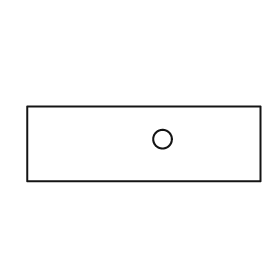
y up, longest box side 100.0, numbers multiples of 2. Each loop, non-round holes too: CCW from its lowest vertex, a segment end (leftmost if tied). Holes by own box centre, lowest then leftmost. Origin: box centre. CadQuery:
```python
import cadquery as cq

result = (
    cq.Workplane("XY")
    .moveTo(-50.0, -16.0)
    .lineTo(50.0, -16.0)
    .lineTo(50.0, 16.0)
    .lineTo(-50.0, 16.0)
    .close()
    .moveTo(8.0, 2.0)
    .circle(4.0)
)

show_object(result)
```